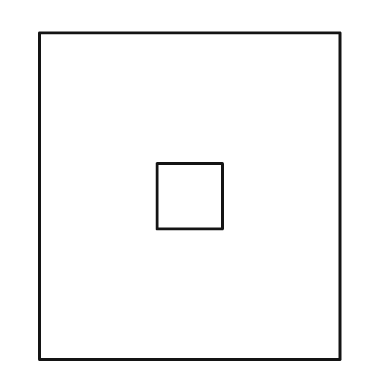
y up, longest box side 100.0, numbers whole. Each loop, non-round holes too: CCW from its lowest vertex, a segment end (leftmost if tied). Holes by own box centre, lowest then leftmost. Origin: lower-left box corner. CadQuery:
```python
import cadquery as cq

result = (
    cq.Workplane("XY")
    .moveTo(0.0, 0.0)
    .lineTo(92.0, 0.0)
    .lineTo(92.0, 100.0)
    .lineTo(0.0, 100.0)
    .close()
    .moveTo(36.0, 40.0)
    .lineTo(56.0, 40.0)
    .lineTo(56.0, 60.0)
    .lineTo(36.0, 60.0)
    .close()
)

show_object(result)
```